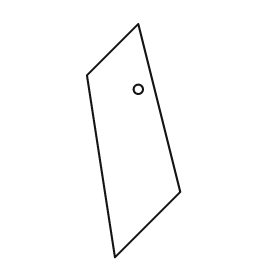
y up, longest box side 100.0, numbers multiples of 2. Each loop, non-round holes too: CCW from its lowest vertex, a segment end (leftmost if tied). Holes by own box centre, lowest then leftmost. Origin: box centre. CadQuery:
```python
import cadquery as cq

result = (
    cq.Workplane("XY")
    .moveTo(-8.0, -50.0)
    .lineTo(20.0, -22.0)
    .lineTo(2.0, 50.0)
    .lineTo(-20.0, 28.0)
    .close()
    .moveTo(2.0, 22.0)
    .circle(2.0)
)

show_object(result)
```